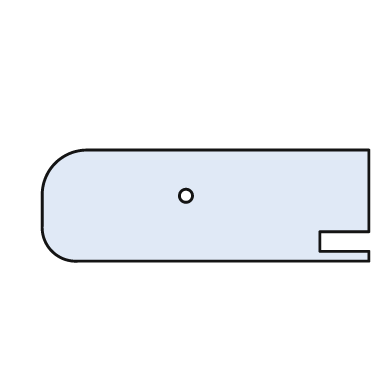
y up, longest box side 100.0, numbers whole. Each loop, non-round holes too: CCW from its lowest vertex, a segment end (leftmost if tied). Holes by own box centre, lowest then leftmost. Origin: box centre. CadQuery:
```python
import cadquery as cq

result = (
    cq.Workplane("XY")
    .moveTo(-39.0, -17.0)
    .lineTo(50.0, -17.0)
    .lineTo(50.0, -14.0)
    .lineTo(35.0, -14.0)
    .lineTo(35.0, -8.0)
    .lineTo(50.0, -8.0)
    .lineTo(50.0, 17.0)
    .lineTo(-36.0, 17.0)
    .threePointArc((-46.0, 13.0), (-50.0, 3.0))
    .lineTo(-50.0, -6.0)
    .threePointArc((-47.0, -14.0), (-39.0, -17.0))
    .close()
    .moveTo(-6.0, 3.0)
    .circle(2.0)
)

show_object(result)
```